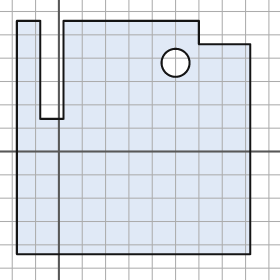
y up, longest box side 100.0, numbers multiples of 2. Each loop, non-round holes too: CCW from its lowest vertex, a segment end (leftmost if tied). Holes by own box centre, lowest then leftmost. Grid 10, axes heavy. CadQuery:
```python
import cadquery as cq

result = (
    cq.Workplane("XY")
    .moveTo(-18.0, -44.0)
    .lineTo(82.0, -44.0)
    .lineTo(82.0, 46.0)
    .lineTo(60.0, 46.0)
    .lineTo(60.0, 56.0)
    .lineTo(2.0, 56.0)
    .lineTo(2.0, 14.0)
    .lineTo(-8.0, 14.0)
    .lineTo(-8.0, 56.0)
    .lineTo(-18.0, 56.0)
    .close()
    .moveTo(50.0, 38.0)
    .circle(6.0)
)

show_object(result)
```